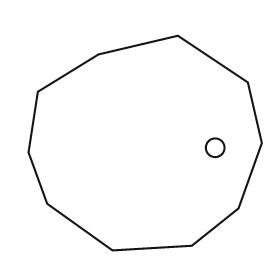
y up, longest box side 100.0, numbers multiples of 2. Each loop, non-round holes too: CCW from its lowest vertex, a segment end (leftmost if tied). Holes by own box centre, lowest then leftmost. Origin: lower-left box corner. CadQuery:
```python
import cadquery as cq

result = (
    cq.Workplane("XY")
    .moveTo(36.0, 0.0)
    .lineTo(70.0, 2.0)
    .lineTo(90.0, 18.0)
    .lineTo(100.0, 46.0)
    .lineTo(94.0, 72.0)
    .lineTo(64.0, 92.0)
    .lineTo(30.0, 84.0)
    .lineTo(4.0, 68.0)
    .lineTo(0.0, 42.0)
    .lineTo(8.0, 20.0)
    .close()
    .moveTo(80.0, 44.0)
    .circle(4.0)
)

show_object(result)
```